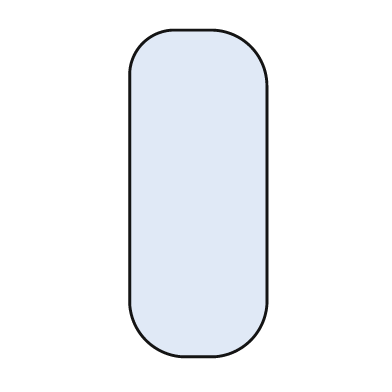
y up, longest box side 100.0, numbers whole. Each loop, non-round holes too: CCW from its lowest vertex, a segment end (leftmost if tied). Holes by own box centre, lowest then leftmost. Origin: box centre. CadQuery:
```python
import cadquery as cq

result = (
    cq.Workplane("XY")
    .moveTo(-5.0, -50.0)
    .lineTo(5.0, -50.0)
    .threePointArc((16.0, -45.0), (21.0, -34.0))
    .lineTo(21.0, 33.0)
    .threePointArc((16.0, 45.0), (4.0, 50.0))
    .lineTo(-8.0, 50.0)
    .threePointArc((-17.0, 46.0), (-21.0, 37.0))
    .lineTo(-21.0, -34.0)
    .threePointArc((-16.0, -45.0), (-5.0, -50.0))
    .close()
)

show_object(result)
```